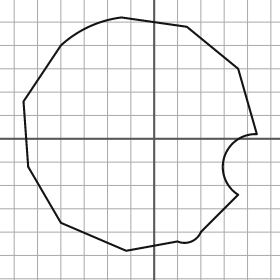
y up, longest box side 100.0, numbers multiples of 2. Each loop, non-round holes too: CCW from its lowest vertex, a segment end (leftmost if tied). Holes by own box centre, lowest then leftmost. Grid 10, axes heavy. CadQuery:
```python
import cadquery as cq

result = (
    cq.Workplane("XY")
    .moveTo(-12.0, -48.0)
    .lineTo(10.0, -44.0)
    .threePointArc((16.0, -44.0), (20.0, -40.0))
    .lineTo(36.0, -24.0)
    .threePointArc((30.0, -8.0), (44.0, 2.0))
    .lineTo(36.0, 30.0)
    .lineTo(14.0, 48.0)
    .lineTo(-14.0, 52.0)
    .threePointArc((-28.0, 48.0), (-40.0, 40.0))
    .lineTo(-56.0, 16.0)
    .lineTo(-54.0, -12.0)
    .lineTo(-40.0, -36.0)
    .close()
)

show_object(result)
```